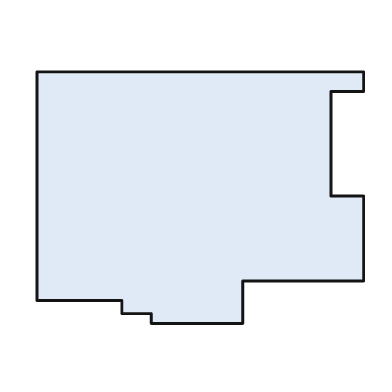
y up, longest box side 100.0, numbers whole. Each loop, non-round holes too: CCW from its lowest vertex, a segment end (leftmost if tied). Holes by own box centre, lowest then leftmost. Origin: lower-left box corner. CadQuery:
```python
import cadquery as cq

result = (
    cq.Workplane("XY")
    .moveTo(35.0, 0.0)
    .lineTo(63.0, 0.0)
    .lineTo(63.0, 13.0)
    .lineTo(100.0, 13.0)
    .lineTo(100.0, 39.0)
    .lineTo(90.0, 39.0)
    .lineTo(90.0, 71.0)
    .lineTo(100.0, 71.0)
    .lineTo(100.0, 77.0)
    .lineTo(0.0, 77.0)
    .lineTo(0.0, 7.0)
    .lineTo(26.0, 7.0)
    .lineTo(26.0, 3.0)
    .lineTo(35.0, 3.0)
    .close()
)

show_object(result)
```